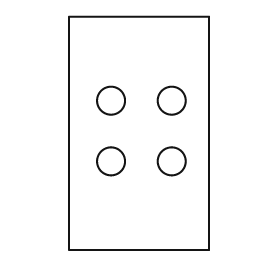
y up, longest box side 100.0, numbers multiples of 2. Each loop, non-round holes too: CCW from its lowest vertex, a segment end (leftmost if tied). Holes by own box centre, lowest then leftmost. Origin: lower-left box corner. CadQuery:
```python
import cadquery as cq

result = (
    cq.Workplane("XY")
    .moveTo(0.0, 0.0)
    .lineTo(60.0, 0.0)
    .lineTo(60.0, 100.0)
    .lineTo(0.0, 100.0)
    .close()
    .moveTo(18.0, 38.0)
    .circle(6.0)
    .moveTo(44.0, 38.0)
    .circle(6.0)
    .moveTo(18.0, 64.0)
    .circle(6.0)
    .moveTo(44.0, 64.0)
    .circle(6.0)
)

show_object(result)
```